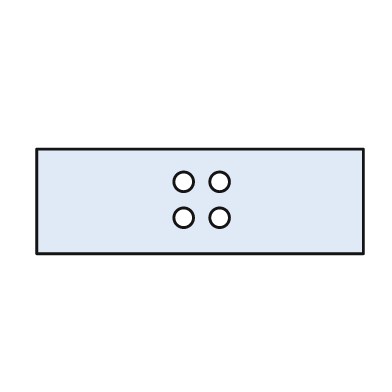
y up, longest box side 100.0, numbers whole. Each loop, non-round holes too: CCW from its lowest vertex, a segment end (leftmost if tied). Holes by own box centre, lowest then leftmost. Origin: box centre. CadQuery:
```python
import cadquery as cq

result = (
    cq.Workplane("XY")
    .moveTo(-50.0, -16.0)
    .lineTo(50.0, -16.0)
    .lineTo(50.0, 16.0)
    .lineTo(-50.0, 16.0)
    .close()
    .moveTo(-5.0, -5.0)
    .circle(3.0)
    .moveTo(6.0, -5.0)
    .circle(3.0)
    .moveTo(-5.0, 6.0)
    .circle(3.0)
    .moveTo(6.0, 6.0)
    .circle(3.0)
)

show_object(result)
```